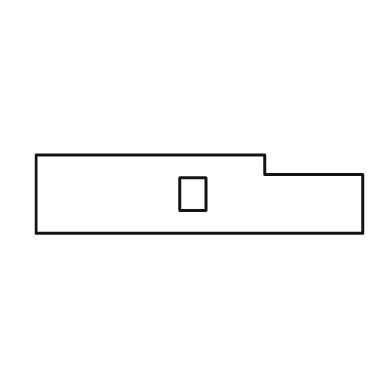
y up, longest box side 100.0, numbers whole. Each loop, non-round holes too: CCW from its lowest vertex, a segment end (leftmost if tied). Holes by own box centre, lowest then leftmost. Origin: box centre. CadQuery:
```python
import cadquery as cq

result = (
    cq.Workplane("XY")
    .moveTo(-50.0, -12.0)
    .lineTo(50.0, -12.0)
    .lineTo(50.0, 6.0)
    .lineTo(20.0, 6.0)
    .lineTo(20.0, 12.0)
    .lineTo(-50.0, 12.0)
    .close()
    .moveTo(-6.0, -5.0)
    .lineTo(2.0, -5.0)
    .lineTo(2.0, 5.0)
    .lineTo(-6.0, 5.0)
    .close()
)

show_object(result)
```